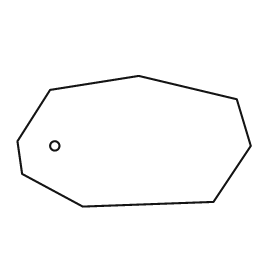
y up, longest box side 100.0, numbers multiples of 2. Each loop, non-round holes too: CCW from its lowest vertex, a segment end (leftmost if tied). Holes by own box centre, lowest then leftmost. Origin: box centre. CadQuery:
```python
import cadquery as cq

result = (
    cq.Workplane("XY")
    .moveTo(-22.0, -28.0)
    .lineTo(34.0, -26.0)
    .lineTo(50.0, -2.0)
    .lineTo(44.0, 18.0)
    .lineTo(2.0, 28.0)
    .lineTo(-36.0, 22.0)
    .lineTo(-50.0, 0.0)
    .lineTo(-48.0, -14.0)
    .close()
    .moveTo(-34.0, -2.0)
    .circle(2.0)
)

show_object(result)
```